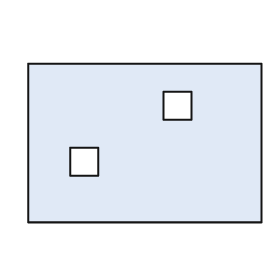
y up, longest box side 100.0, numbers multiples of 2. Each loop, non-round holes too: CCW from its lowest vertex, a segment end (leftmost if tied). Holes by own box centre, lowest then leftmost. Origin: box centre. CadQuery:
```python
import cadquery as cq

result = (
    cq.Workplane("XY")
    .moveTo(-50.0, -34.0)
    .lineTo(50.0, -34.0)
    .lineTo(50.0, 34.0)
    .lineTo(-50.0, 34.0)
    .close()
    .moveTo(-32.0, -14.0)
    .lineTo(-20.0, -14.0)
    .lineTo(-20.0, -2.0)
    .lineTo(-32.0, -2.0)
    .close()
    .moveTo(8.0, 10.0)
    .lineTo(20.0, 10.0)
    .lineTo(20.0, 22.0)
    .lineTo(8.0, 22.0)
    .close()
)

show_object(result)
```